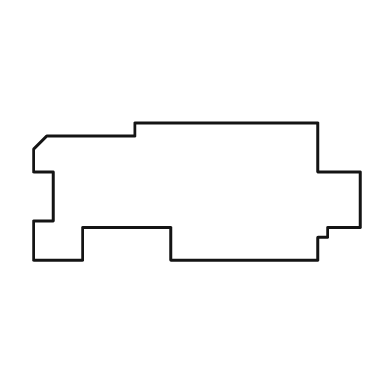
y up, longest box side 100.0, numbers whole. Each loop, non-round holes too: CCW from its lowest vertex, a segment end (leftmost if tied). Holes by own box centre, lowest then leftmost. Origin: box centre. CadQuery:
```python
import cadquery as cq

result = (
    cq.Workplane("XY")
    .moveTo(-50.0, -21.0)
    .lineTo(-35.0, -21.0)
    .lineTo(-35.0, -11.0)
    .lineTo(-8.0, -11.0)
    .lineTo(-8.0, -21.0)
    .lineTo(37.0, -21.0)
    .lineTo(37.0, -14.0)
    .lineTo(40.0, -14.0)
    .lineTo(40.0, -11.0)
    .lineTo(50.0, -11.0)
    .lineTo(50.0, 6.0)
    .lineTo(37.0, 6.0)
    .lineTo(37.0, 21.0)
    .lineTo(-19.0, 21.0)
    .lineTo(-19.0, 17.0)
    .lineTo(-46.0, 17.0)
    .lineTo(-50.0, 13.0)
    .lineTo(-50.0, 6.0)
    .lineTo(-44.0, 6.0)
    .lineTo(-44.0, -9.0)
    .lineTo(-50.0, -9.0)
    .close()
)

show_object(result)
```